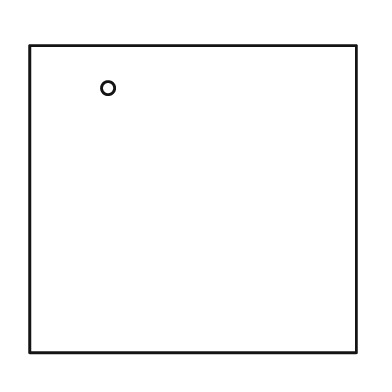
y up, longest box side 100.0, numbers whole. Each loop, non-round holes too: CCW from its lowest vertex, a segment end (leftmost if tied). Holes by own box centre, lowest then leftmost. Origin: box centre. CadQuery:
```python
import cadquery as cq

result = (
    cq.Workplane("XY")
    .moveTo(-50.0, -47.0)
    .lineTo(50.0, -47.0)
    .lineTo(50.0, 47.0)
    .lineTo(-50.0, 47.0)
    .close()
    .moveTo(-26.0, 34.0)
    .circle(2.0)
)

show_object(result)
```